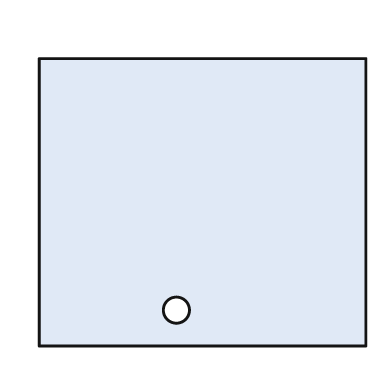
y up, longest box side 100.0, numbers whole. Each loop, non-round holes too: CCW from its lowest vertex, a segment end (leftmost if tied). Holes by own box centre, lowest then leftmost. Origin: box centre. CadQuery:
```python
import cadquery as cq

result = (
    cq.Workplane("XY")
    .moveTo(-50.0, -44.0)
    .lineTo(50.0, -44.0)
    .lineTo(50.0, 44.0)
    .lineTo(-50.0, 44.0)
    .close()
    .moveTo(-8.0, -33.0)
    .circle(4.0)
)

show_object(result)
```